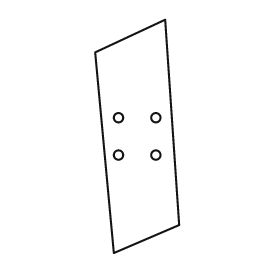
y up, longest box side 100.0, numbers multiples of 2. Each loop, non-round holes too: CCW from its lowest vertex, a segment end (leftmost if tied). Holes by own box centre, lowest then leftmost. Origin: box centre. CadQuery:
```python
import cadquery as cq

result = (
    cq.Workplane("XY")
    .moveTo(-10.0, -50.0)
    .lineTo(18.0, -38.0)
    .lineTo(12.0, 50.0)
    .lineTo(-18.0, 36.0)
    .close()
    .moveTo(-8.0, -8.0)
    .circle(2.0)
    .moveTo(8.0, -8.0)
    .circle(2.0)
    .moveTo(-8.0, 8.0)
    .circle(2.0)
    .moveTo(8.0, 8.0)
    .circle(2.0)
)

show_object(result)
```